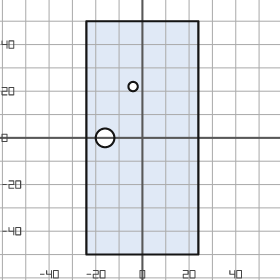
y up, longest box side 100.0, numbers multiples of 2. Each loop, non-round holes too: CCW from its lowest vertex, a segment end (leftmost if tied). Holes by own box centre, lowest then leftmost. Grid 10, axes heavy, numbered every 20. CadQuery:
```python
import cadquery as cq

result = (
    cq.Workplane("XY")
    .moveTo(-24.0, -50.0)
    .lineTo(24.0, -50.0)
    .lineTo(24.0, 50.0)
    .lineTo(-24.0, 50.0)
    .close()
    .moveTo(-16.0, 0.0)
    .circle(4.0)
    .moveTo(-4.0, 22.0)
    .circle(2.0)
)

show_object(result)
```